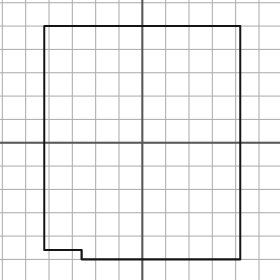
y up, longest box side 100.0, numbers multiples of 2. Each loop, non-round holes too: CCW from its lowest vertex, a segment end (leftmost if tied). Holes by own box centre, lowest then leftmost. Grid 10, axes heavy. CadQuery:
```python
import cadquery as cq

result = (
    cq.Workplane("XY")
    .moveTo(-26.0, -50.0)
    .lineTo(42.0, -50.0)
    .lineTo(42.0, 50.0)
    .lineTo(-42.0, 50.0)
    .lineTo(-42.0, -46.0)
    .lineTo(-26.0, -46.0)
    .close()
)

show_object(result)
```